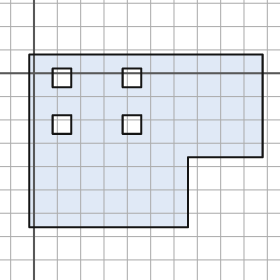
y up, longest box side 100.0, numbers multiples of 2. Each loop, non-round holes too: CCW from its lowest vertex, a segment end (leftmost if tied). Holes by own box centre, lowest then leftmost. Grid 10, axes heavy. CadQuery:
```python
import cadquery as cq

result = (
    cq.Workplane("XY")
    .moveTo(-2.0, -66.0)
    .lineTo(66.0, -66.0)
    .lineTo(66.0, -36.0)
    .lineTo(98.0, -36.0)
    .lineTo(98.0, 8.0)
    .lineTo(-2.0, 8.0)
    .close()
    .moveTo(8.0, -26.0)
    .lineTo(16.0, -26.0)
    .lineTo(16.0, -18.0)
    .lineTo(8.0, -18.0)
    .close()
    .moveTo(38.0, -26.0)
    .lineTo(46.0, -26.0)
    .lineTo(46.0, -18.0)
    .lineTo(38.0, -18.0)
    .close()
    .moveTo(8.0, -6.0)
    .lineTo(16.0, -6.0)
    .lineTo(16.0, 2.0)
    .lineTo(8.0, 2.0)
    .close()
    .moveTo(38.0, -6.0)
    .lineTo(46.0, -6.0)
    .lineTo(46.0, 2.0)
    .lineTo(38.0, 2.0)
    .close()
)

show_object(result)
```